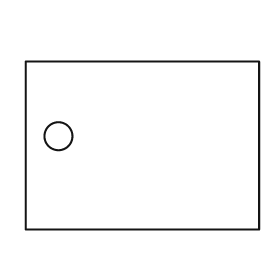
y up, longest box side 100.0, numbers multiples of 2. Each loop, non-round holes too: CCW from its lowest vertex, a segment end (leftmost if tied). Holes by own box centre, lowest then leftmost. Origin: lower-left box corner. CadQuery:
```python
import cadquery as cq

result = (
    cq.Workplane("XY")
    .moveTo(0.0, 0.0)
    .lineTo(100.0, 0.0)
    .lineTo(100.0, 72.0)
    .lineTo(0.0, 72.0)
    .close()
    .moveTo(14.0, 40.0)
    .circle(6.0)
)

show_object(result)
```